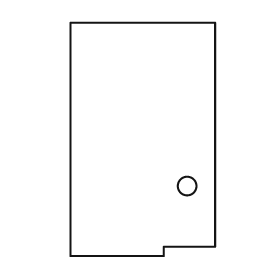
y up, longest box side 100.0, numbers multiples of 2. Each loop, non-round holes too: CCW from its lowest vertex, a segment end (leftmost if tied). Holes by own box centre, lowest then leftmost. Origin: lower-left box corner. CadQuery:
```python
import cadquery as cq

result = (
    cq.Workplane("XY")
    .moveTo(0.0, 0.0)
    .lineTo(40.0, 0.0)
    .lineTo(40.0, 4.0)
    .lineTo(62.0, 4.0)
    .lineTo(62.0, 100.0)
    .lineTo(0.0, 100.0)
    .close()
    .moveTo(50.0, 30.0)
    .circle(4.0)
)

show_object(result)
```